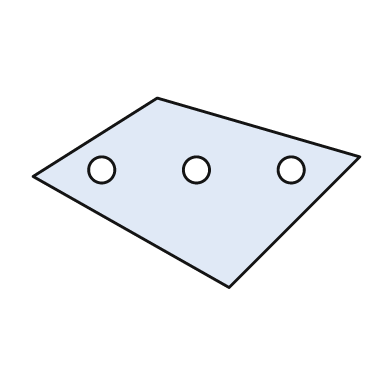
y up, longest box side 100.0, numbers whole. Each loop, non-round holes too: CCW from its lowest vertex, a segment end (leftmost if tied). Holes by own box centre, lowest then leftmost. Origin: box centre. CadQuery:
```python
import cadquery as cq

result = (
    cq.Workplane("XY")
    .moveTo(10.0, -29.0)
    .lineTo(50.0, 11.0)
    .lineTo(-12.0, 29.0)
    .lineTo(-50.0, 5.0)
    .close()
    .moveTo(-29.0, 7.0)
    .circle(4.0)
    .moveTo(0.0, 7.0)
    .circle(4.0)
    .moveTo(29.0, 7.0)
    .circle(4.0)
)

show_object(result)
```